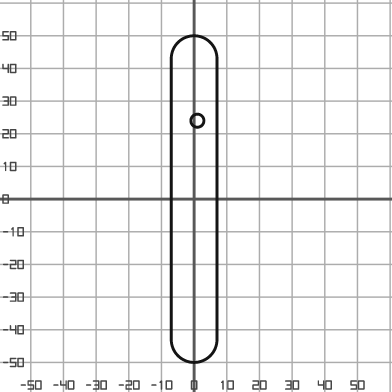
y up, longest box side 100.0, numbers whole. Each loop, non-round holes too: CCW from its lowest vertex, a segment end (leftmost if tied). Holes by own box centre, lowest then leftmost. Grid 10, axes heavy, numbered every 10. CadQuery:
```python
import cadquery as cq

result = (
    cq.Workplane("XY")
    .moveTo(-7.0, -43.0)
    .threePointArc((0.0, -50.0), (7.0, -43.0))
    .lineTo(7.0, 43.0)
    .threePointArc((0.0, 50.0), (-7.0, 43.0))
    .close()
    .moveTo(1.0, 24.0)
    .circle(2.0)
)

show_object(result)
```